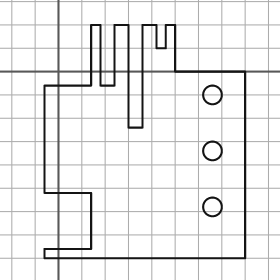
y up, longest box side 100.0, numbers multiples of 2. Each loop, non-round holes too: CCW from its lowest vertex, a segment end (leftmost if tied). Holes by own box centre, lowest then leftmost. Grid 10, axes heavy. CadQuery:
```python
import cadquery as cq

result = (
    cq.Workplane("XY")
    .moveTo(-6.0, -80.0)
    .lineTo(80.0, -80.0)
    .lineTo(80.0, 0.0)
    .lineTo(50.0, 0.0)
    .lineTo(50.0, 20.0)
    .lineTo(46.0, 20.0)
    .lineTo(46.0, 10.0)
    .lineTo(42.0, 10.0)
    .lineTo(42.0, 20.0)
    .lineTo(36.0, 20.0)
    .lineTo(36.0, -24.0)
    .lineTo(30.0, -24.0)
    .lineTo(30.0, 20.0)
    .lineTo(24.0, 20.0)
    .lineTo(24.0, -6.0)
    .lineTo(18.0, -6.0)
    .lineTo(18.0, 20.0)
    .lineTo(14.0, 20.0)
    .lineTo(14.0, -6.0)
    .lineTo(-6.0, -6.0)
    .lineTo(-6.0, -52.0)
    .lineTo(14.0, -52.0)
    .lineTo(14.0, -76.0)
    .lineTo(-6.0, -76.0)
    .close()
    .moveTo(66.0, -58.0)
    .circle(4.0)
    .moveTo(66.0, -34.0)
    .circle(4.0)
    .moveTo(66.0, -10.0)
    .circle(4.0)
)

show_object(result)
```